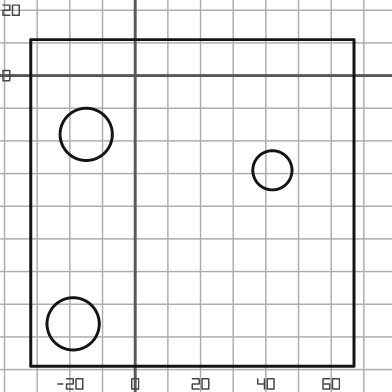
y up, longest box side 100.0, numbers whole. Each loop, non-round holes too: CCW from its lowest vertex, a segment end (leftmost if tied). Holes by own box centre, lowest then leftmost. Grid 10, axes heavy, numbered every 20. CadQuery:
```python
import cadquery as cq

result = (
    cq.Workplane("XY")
    .moveTo(-32.0, -89.0)
    .lineTo(67.0, -89.0)
    .lineTo(67.0, 11.0)
    .lineTo(-32.0, 11.0)
    .close()
    .moveTo(-19.0, -76.0)
    .circle(8.0)
    .moveTo(42.0, -29.0)
    .circle(6.0)
    .moveTo(-15.0, -18.0)
    .circle(8.0)
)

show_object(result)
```